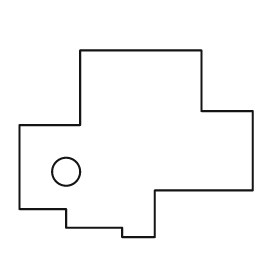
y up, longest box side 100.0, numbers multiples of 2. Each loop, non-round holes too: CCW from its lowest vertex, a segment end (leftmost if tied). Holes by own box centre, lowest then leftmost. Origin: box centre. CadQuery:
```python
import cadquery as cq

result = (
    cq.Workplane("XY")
    .moveTo(-6.0, -40.0)
    .lineTo(8.0, -40.0)
    .lineTo(8.0, -20.0)
    .lineTo(50.0, -20.0)
    .lineTo(50.0, 14.0)
    .lineTo(28.0, 14.0)
    .lineTo(28.0, 40.0)
    .lineTo(-24.0, 40.0)
    .lineTo(-24.0, 8.0)
    .lineTo(-50.0, 8.0)
    .lineTo(-50.0, -28.0)
    .lineTo(-30.0, -28.0)
    .lineTo(-30.0, -36.0)
    .lineTo(-6.0, -36.0)
    .close()
    .moveTo(-30.0, -12.0)
    .circle(6.0)
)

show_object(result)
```